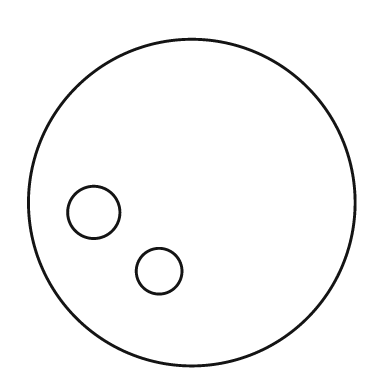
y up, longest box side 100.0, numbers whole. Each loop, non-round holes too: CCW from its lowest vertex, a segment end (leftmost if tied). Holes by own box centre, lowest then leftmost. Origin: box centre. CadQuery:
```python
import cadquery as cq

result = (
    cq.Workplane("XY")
    .moveTo(0.0, 0.0)
    .circle(50.0)
    .moveTo(-10.0, -21.0)
    .circle(7.0)
    .moveTo(-30.0, -3.0)
    .circle(8.0)
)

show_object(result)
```